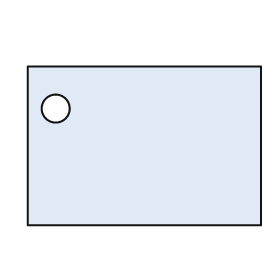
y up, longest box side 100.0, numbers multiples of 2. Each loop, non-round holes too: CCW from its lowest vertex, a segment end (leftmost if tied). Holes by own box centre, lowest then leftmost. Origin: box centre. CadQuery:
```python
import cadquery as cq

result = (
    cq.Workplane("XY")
    .moveTo(-50.0, -34.0)
    .lineTo(50.0, -34.0)
    .lineTo(50.0, 34.0)
    .lineTo(-50.0, 34.0)
    .close()
    .moveTo(-38.0, 16.0)
    .circle(6.0)
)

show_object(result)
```